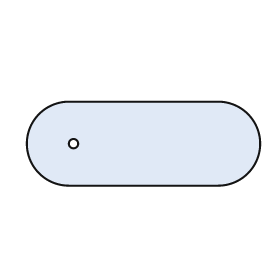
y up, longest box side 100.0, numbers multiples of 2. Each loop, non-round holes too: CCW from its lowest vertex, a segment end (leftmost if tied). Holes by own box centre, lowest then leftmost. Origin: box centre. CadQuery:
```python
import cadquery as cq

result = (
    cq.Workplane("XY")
    .moveTo(-32.0, -18.0)
    .lineTo(32.0, -18.0)
    .threePointArc((50.0, 0.0), (32.0, 18.0))
    .lineTo(-32.0, 18.0)
    .threePointArc((-50.0, 0.0), (-32.0, -18.0))
    .close()
    .moveTo(-30.0, 0.0)
    .circle(2.0)
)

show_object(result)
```